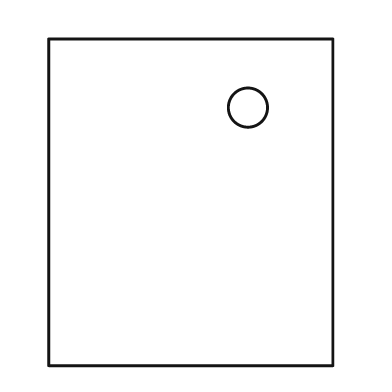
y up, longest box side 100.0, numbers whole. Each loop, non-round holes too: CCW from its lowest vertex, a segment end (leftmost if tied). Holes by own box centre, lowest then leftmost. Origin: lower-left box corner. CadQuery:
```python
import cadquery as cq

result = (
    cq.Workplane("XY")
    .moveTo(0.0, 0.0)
    .lineTo(87.0, 0.0)
    .lineTo(87.0, 100.0)
    .lineTo(0.0, 100.0)
    .close()
    .moveTo(61.0, 79.0)
    .circle(6.0)
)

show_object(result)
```